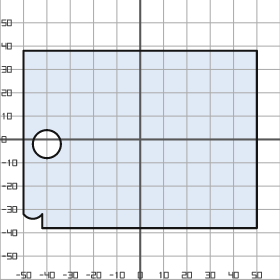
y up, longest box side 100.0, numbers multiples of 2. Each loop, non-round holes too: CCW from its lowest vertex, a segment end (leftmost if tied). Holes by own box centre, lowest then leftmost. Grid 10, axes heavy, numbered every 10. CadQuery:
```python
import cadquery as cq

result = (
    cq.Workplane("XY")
    .moveTo(-42.0, -38.0)
    .lineTo(50.0, -38.0)
    .lineTo(50.0, 38.0)
    .lineTo(-50.0, 38.0)
    .lineTo(-50.0, -32.0)
    .threePointArc((-46.0, -34.0), (-42.0, -32.0))
    .close()
    .moveTo(-40.0, -2.0)
    .circle(6.0)
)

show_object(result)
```